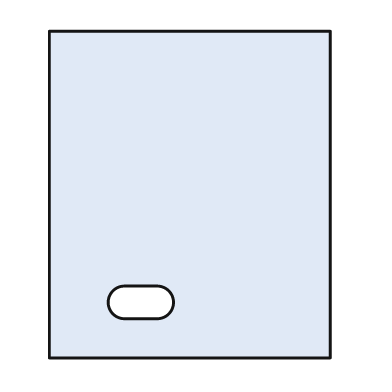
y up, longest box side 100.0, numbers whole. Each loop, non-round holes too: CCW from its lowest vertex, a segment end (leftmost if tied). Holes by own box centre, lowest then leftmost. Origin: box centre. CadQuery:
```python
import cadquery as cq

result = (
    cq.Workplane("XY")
    .moveTo(-43.0, -50.0)
    .lineTo(43.0, -50.0)
    .lineTo(43.0, 50.0)
    .lineTo(-43.0, 50.0)
    .close()
    .moveTo(-20.0, -38.0)
    .lineTo(-10.0, -38.0)
    .threePointArc((-5.0, -33.0), (-10.0, -28.0))
    .lineTo(-20.0, -28.0)
    .threePointArc((-25.0, -33.0), (-20.0, -38.0))
    .close()
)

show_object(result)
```